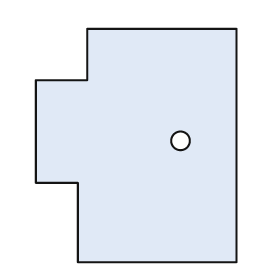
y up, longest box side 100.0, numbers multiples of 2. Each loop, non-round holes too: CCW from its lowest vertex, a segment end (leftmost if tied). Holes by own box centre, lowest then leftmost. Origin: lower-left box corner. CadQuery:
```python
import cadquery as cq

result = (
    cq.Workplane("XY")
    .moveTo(18.0, 0.0)
    .lineTo(86.0, 0.0)
    .lineTo(86.0, 100.0)
    .lineTo(22.0, 100.0)
    .lineTo(22.0, 78.0)
    .lineTo(0.0, 78.0)
    .lineTo(0.0, 34.0)
    .lineTo(18.0, 34.0)
    .close()
    .moveTo(62.0, 52.0)
    .circle(4.0)
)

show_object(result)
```